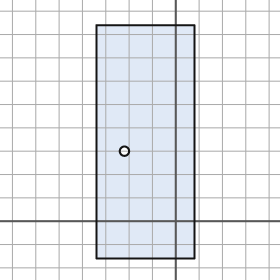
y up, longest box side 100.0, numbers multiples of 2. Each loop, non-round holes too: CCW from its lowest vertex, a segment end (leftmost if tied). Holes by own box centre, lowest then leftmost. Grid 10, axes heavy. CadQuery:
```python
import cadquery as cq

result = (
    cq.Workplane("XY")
    .moveTo(-34.0, -16.0)
    .lineTo(8.0, -16.0)
    .lineTo(8.0, 84.0)
    .lineTo(-34.0, 84.0)
    .close()
    .moveTo(-22.0, 30.0)
    .circle(2.0)
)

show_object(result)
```